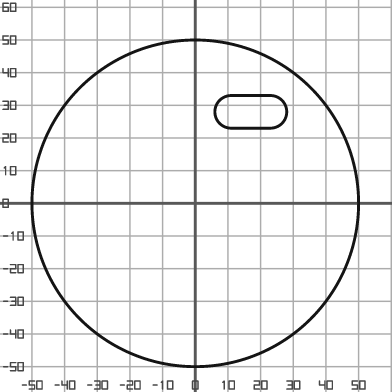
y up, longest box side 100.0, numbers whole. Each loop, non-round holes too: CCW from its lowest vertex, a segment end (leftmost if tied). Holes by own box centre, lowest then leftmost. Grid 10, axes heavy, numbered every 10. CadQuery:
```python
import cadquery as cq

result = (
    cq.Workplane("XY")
    .moveTo(0.0, 0.0)
    .circle(50.0)
    .moveTo(11.0, 23.0)
    .lineTo(23.0, 23.0)
    .threePointArc((28.0, 28.0), (23.0, 33.0))
    .lineTo(11.0, 33.0)
    .threePointArc((6.0, 28.0), (11.0, 23.0))
    .close()
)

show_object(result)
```